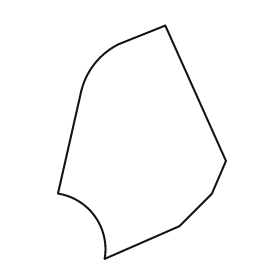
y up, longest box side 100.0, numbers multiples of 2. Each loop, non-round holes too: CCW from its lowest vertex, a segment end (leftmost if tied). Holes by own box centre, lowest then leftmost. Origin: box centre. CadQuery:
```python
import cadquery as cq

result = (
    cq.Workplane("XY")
    .moveTo(-16.0, -50.0)
    .lineTo(16.0, -36.0)
    .lineTo(30.0, -22.0)
    .lineTo(36.0, -8.0)
    .lineTo(10.0, 50.0)
    .lineTo(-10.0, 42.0)
    .threePointArc((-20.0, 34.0), (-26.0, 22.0))
    .lineTo(-36.0, -22.0)
    .threePointArc((-20.0, -32.0), (-16.0, -50.0))
    .close()
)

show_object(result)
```